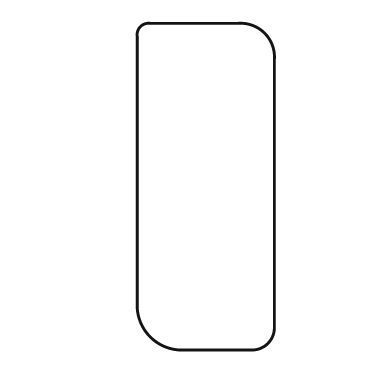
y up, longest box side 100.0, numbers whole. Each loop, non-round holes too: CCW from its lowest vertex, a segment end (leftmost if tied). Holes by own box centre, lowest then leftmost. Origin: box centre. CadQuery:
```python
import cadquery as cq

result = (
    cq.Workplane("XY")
    .moveTo(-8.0, -50.0)
    .lineTo(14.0, -50.0)
    .threePointArc((19.0, -48.0), (21.0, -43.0))
    .lineTo(21.0, 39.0)
    .threePointArc((18.0, 47.0), (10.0, 50.0))
    .lineTo(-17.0, 50.0)
    .threePointArc((-20.0, 49.0), (-21.0, 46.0))
    .lineTo(-21.0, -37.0)
    .threePointArc((-17.0, -46.0), (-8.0, -50.0))
    .close()
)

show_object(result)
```